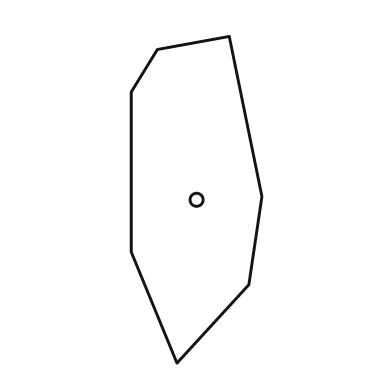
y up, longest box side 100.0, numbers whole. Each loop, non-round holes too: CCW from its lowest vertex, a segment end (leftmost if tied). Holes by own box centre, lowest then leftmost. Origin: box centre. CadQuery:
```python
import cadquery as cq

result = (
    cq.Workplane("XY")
    .moveTo(-6.0, -50.0)
    .lineTo(16.0, -26.0)
    .lineTo(20.0, 1.0)
    .lineTo(10.0, 50.0)
    .lineTo(-12.0, 46.0)
    .lineTo(-20.0, 33.0)
    .lineTo(-20.0, -16.0)
    .close()
    .moveTo(0.0, 0.0)
    .circle(2.0)
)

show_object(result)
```